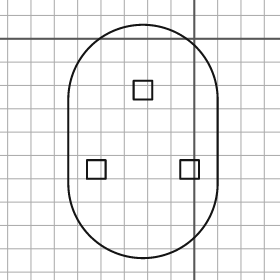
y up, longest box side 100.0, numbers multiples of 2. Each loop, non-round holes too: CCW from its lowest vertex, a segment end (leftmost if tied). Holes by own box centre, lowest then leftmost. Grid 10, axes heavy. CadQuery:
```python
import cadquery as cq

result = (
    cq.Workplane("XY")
    .moveTo(-54.0, -62.0)
    .threePointArc((-22.0, -94.0), (10.0, -62.0))
    .lineTo(10.0, -26.0)
    .threePointArc((-22.0, 6.0), (-54.0, -26.0))
    .close()
    .moveTo(-46.0, -60.0)
    .lineTo(-38.0, -60.0)
    .lineTo(-38.0, -52.0)
    .lineTo(-46.0, -52.0)
    .close()
    .moveTo(-6.0, -60.0)
    .lineTo(2.0, -60.0)
    .lineTo(2.0, -52.0)
    .lineTo(-6.0, -52.0)
    .close()
    .moveTo(-26.0, -26.0)
    .lineTo(-18.0, -26.0)
    .lineTo(-18.0, -18.0)
    .lineTo(-26.0, -18.0)
    .close()
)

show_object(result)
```